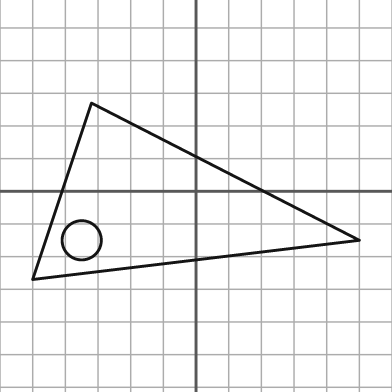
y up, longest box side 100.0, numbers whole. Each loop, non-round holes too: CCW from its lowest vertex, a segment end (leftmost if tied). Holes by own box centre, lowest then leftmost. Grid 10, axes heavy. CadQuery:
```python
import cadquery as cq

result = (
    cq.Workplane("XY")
    .moveTo(-50.0, -27.0)
    .lineTo(50.0, -15.0)
    .lineTo(-32.0, 27.0)
    .close()
    .moveTo(-35.0, -15.0)
    .circle(6.0)
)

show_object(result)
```